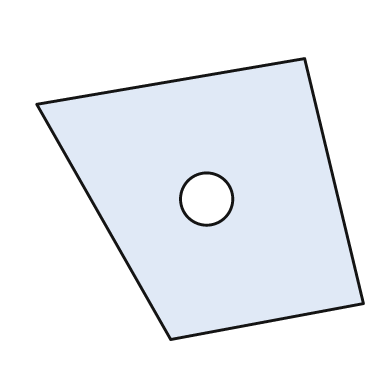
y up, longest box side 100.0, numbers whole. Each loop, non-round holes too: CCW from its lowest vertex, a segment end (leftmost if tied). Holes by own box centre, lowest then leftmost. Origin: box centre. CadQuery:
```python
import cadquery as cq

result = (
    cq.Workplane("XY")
    .moveTo(-9.0, -43.0)
    .lineTo(50.0, -32.0)
    .lineTo(32.0, 43.0)
    .lineTo(-50.0, 29.0)
    .close()
    .moveTo(2.0, 0.0)
    .circle(8.0)
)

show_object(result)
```